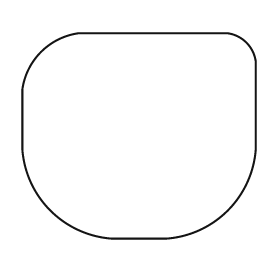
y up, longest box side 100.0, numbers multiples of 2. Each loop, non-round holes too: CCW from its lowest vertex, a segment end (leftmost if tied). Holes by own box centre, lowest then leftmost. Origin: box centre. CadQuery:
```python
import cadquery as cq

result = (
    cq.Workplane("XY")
    .moveTo(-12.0, -44.0)
    .lineTo(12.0, -44.0)
    .threePointArc((38.0, -32.0), (50.0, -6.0))
    .lineTo(50.0, 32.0)
    .threePointArc((46.0, 40.0), (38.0, 44.0))
    .lineTo(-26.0, 44.0)
    .threePointArc((-42.0, 36.0), (-50.0, 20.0))
    .lineTo(-50.0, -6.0)
    .threePointArc((-38.0, -32.0), (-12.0, -44.0))
    .close()
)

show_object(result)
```